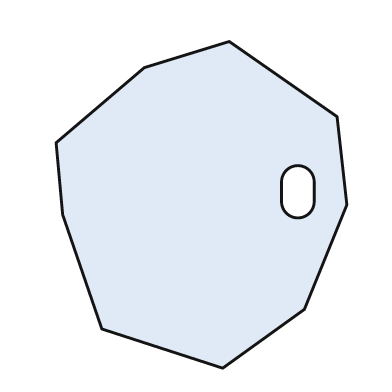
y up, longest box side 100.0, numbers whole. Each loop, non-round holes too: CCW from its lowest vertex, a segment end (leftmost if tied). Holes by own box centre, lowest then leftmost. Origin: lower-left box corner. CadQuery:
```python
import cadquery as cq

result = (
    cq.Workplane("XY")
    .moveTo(51.0, 0.0)
    .lineTo(76.0, 18.0)
    .lineTo(89.0, 50.0)
    .lineTo(86.0, 77.0)
    .lineTo(53.0, 100.0)
    .lineTo(27.0, 92.0)
    .lineTo(0.0, 69.0)
    .lineTo(2.0, 47.0)
    .lineTo(14.0, 12.0)
    .close()
    .moveTo(69.0, 51.0)
    .threePointArc((74.0, 46.0), (79.0, 51.0))
    .lineTo(79.0, 57.0)
    .threePointArc((74.0, 62.0), (69.0, 57.0))
    .close()
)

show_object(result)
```